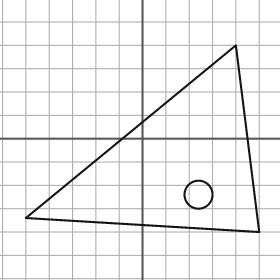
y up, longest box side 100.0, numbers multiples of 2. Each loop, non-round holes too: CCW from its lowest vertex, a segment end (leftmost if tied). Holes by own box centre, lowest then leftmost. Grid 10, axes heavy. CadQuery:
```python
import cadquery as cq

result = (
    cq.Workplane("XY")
    .moveTo(50.0, -40.0)
    .lineTo(40.0, 40.0)
    .lineTo(-50.0, -34.0)
    .close()
    .moveTo(24.0, -24.0)
    .circle(6.0)
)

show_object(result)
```